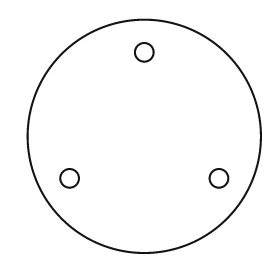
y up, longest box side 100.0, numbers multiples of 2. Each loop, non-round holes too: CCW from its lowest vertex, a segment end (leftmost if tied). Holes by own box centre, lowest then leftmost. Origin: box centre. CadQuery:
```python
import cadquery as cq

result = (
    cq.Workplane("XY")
    .moveTo(0.0, 0.0)
    .circle(50.0)
    .moveTo(-32.0, -18.0)
    .circle(4.0)
    .moveTo(32.0, -18.0)
    .circle(4.0)
    .moveTo(0.0, 36.0)
    .circle(4.0)
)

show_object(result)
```